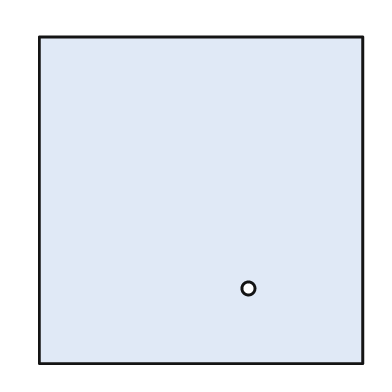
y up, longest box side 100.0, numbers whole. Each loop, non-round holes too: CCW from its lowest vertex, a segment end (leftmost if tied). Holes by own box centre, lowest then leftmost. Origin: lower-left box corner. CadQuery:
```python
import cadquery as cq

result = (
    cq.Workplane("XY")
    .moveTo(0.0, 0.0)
    .lineTo(99.0, 0.0)
    .lineTo(99.0, 100.0)
    .lineTo(0.0, 100.0)
    .close()
    .moveTo(64.0, 23.0)
    .circle(2.0)
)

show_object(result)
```